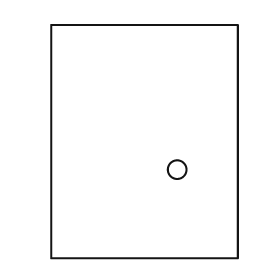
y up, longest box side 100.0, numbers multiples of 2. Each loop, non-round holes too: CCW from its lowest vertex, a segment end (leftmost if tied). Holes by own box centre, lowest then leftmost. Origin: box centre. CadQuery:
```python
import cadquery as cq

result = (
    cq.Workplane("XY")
    .moveTo(-40.0, -50.0)
    .lineTo(40.0, -50.0)
    .lineTo(40.0, 50.0)
    .lineTo(-40.0, 50.0)
    .close()
    .moveTo(14.0, -12.0)
    .circle(4.0)
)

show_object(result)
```